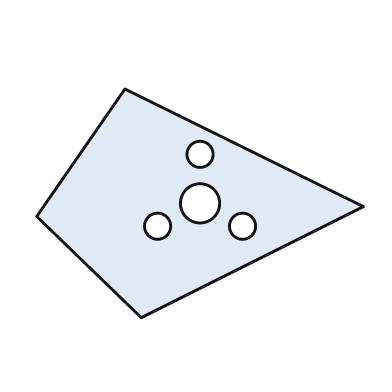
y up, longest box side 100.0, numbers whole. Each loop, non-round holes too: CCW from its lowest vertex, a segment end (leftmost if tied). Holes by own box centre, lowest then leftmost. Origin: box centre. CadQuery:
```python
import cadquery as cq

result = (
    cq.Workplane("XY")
    .moveTo(-18.0, -35.0)
    .lineTo(50.0, -1.0)
    .lineTo(-23.0, 35.0)
    .lineTo(-50.0, -4.0)
    .close()
    .moveTo(-13.0, -7.0)
    .circle(4.0)
    .moveTo(13.0, -7.0)
    .circle(4.0)
    .moveTo(0.0, 0.0)
    .circle(6.0)
    .moveTo(0.0, 15.0)
    .circle(4.0)
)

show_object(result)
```